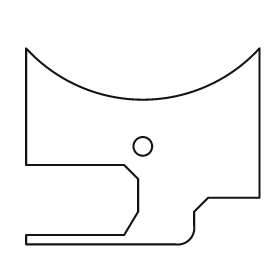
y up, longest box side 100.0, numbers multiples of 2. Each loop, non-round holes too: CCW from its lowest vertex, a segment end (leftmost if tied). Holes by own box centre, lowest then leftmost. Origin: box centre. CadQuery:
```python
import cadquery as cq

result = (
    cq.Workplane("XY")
    .moveTo(-50.0, -42.0)
    .lineTo(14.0, -42.0)
    .threePointArc((20.0, -40.0), (22.0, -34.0))
    .lineTo(22.0, -28.0)
    .lineTo(28.0, -22.0)
    .lineTo(50.0, -22.0)
    .lineTo(50.0, 42.0)
    .threePointArc((0.0, 20.0), (-50.0, 42.0))
    .lineTo(-50.0, -8.0)
    .lineTo(-8.0, -8.0)
    .lineTo(-2.0, -14.0)
    .lineTo(-2.0, -28.0)
    .lineTo(-8.0, -38.0)
    .lineTo(-50.0, -38.0)
    .close()
    .moveTo(0.0, 0.0)
    .circle(4.0)
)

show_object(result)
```